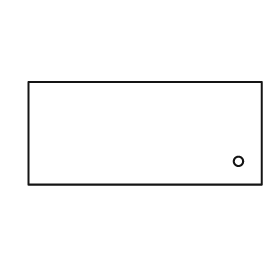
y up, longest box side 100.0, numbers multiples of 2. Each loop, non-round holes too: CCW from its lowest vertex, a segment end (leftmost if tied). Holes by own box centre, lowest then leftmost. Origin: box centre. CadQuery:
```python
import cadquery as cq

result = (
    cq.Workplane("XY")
    .moveTo(-50.0, -22.0)
    .lineTo(50.0, -22.0)
    .lineTo(50.0, 22.0)
    .lineTo(-50.0, 22.0)
    .close()
    .moveTo(40.0, -12.0)
    .circle(2.0)
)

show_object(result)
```